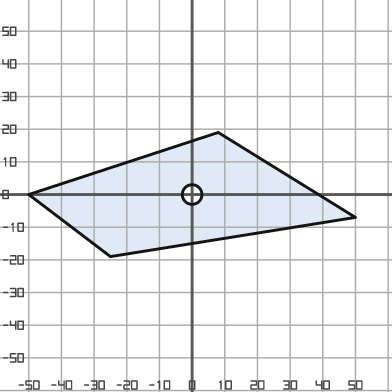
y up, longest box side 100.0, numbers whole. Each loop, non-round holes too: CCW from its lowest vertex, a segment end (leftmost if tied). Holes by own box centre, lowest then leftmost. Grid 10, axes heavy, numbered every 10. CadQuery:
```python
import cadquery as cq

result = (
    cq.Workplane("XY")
    .moveTo(-25.0, -19.0)
    .lineTo(50.0, -7.0)
    .lineTo(8.0, 19.0)
    .lineTo(-50.0, 0.0)
    .close()
    .moveTo(0.0, 0.0)
    .circle(3.0)
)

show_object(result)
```